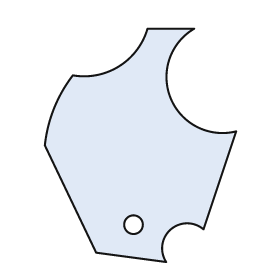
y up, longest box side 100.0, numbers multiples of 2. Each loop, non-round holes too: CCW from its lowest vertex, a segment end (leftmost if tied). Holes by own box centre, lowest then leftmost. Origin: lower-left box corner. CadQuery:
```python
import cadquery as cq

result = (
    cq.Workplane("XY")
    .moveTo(52.0, 0.0)
    .threePointArc((54.0, 14.0), (68.0, 14.0))
    .lineTo(82.0, 56.0)
    .threePointArc((54.0, 70.0), (64.0, 100.0))
    .lineTo(44.0, 100.0)
    .threePointArc((32.0, 84.0), (12.0, 80.0))
    .threePointArc((4.0, 66.0), (0.0, 50.0))
    .lineTo(22.0, 4.0)
    .close()
    .moveTo(38.0, 16.0)
    .circle(4.0)
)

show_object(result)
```